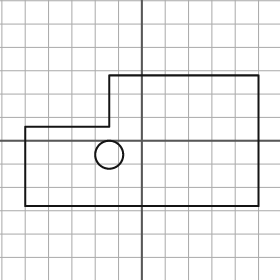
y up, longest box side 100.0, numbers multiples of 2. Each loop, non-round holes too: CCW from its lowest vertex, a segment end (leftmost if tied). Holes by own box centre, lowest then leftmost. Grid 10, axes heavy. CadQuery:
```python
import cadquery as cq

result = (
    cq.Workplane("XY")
    .moveTo(-50.0, -28.0)
    .lineTo(50.0, -28.0)
    .lineTo(50.0, 28.0)
    .lineTo(-14.0, 28.0)
    .lineTo(-14.0, 6.0)
    .lineTo(-50.0, 6.0)
    .close()
    .moveTo(-14.0, -6.0)
    .circle(6.0)
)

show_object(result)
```